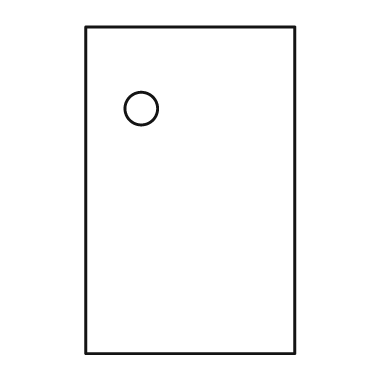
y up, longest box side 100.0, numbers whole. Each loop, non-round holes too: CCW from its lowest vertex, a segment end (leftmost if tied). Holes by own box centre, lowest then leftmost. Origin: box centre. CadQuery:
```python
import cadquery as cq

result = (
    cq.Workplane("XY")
    .moveTo(-32.0, -50.0)
    .lineTo(32.0, -50.0)
    .lineTo(32.0, 50.0)
    .lineTo(-32.0, 50.0)
    .close()
    .moveTo(-15.0, 25.0)
    .circle(5.0)
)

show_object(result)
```